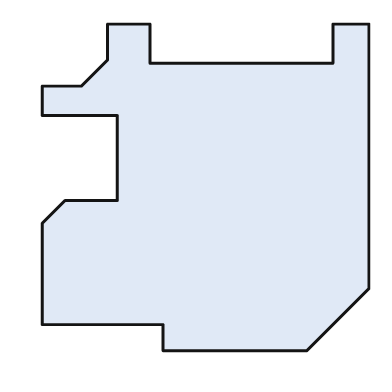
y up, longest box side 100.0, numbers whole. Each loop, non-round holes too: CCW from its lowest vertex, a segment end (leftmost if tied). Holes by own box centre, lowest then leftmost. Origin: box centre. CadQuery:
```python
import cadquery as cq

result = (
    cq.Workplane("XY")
    .moveTo(-13.0, -50.0)
    .lineTo(31.0, -50.0)
    .lineTo(50.0, -31.0)
    .lineTo(50.0, 50.0)
    .lineTo(39.0, 50.0)
    .lineTo(39.0, 38.0)
    .lineTo(-17.0, 38.0)
    .lineTo(-17.0, 50.0)
    .lineTo(-30.0, 50.0)
    .lineTo(-30.0, 39.0)
    .lineTo(-38.0, 31.0)
    .lineTo(-50.0, 31.0)
    .lineTo(-50.0, 22.0)
    .lineTo(-27.0, 22.0)
    .lineTo(-27.0, -4.0)
    .lineTo(-43.0, -4.0)
    .lineTo(-50.0, -11.0)
    .lineTo(-50.0, -42.0)
    .lineTo(-13.0, -42.0)
    .close()
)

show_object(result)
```